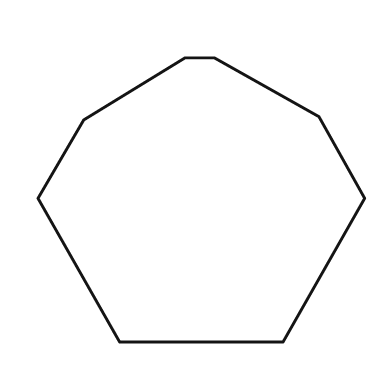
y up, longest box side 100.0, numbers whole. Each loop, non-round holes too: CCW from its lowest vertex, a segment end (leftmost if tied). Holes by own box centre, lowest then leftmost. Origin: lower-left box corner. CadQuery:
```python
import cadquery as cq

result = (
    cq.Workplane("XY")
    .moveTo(25.0, 0.0)
    .lineTo(75.0, 0.0)
    .lineTo(100.0, 44.0)
    .lineTo(86.0, 69.0)
    .lineTo(54.0, 87.0)
    .lineTo(45.0, 87.0)
    .lineTo(14.0, 68.0)
    .lineTo(0.0, 44.0)
    .close()
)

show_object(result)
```